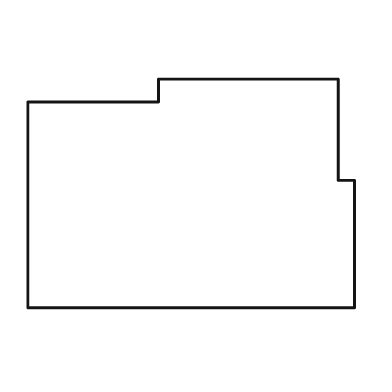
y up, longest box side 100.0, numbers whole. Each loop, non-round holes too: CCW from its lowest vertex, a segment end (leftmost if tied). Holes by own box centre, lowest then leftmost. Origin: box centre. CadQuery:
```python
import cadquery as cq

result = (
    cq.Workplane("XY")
    .moveTo(-50.0, -35.0)
    .lineTo(50.0, -35.0)
    .lineTo(50.0, 4.0)
    .lineTo(45.0, 4.0)
    .lineTo(45.0, 35.0)
    .lineTo(-10.0, 35.0)
    .lineTo(-10.0, 28.0)
    .lineTo(-50.0, 28.0)
    .close()
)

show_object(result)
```